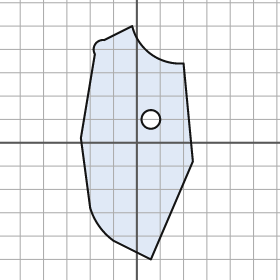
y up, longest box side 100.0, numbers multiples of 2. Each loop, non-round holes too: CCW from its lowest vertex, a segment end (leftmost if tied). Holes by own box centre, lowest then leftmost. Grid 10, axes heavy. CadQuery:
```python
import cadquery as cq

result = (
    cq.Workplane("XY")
    .moveTo(6.0, -50.0)
    .lineTo(24.0, -8.0)
    .lineTo(20.0, 34.0)
    .threePointArc((6.0, 38.0), (-2.0, 50.0))
    .lineTo(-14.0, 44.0)
    .threePointArc((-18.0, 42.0), (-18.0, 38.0))
    .lineTo(-24.0, 2.0)
    .lineTo(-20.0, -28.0)
    .threePointArc((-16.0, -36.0), (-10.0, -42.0))
    .close()
    .moveTo(6.0, 10.0)
    .circle(4.0)
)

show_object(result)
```